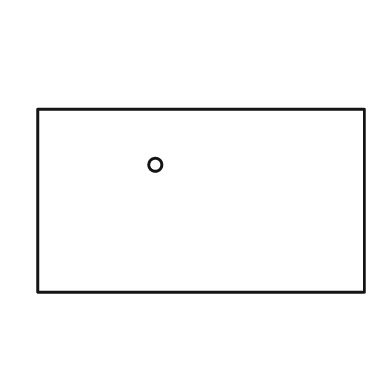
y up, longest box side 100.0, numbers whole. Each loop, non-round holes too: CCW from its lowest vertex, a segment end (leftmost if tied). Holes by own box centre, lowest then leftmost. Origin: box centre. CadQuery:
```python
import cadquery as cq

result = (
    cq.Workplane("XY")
    .moveTo(-50.0, -28.0)
    .lineTo(50.0, -28.0)
    .lineTo(50.0, 28.0)
    .lineTo(-50.0, 28.0)
    .close()
    .moveTo(-14.0, 11.0)
    .circle(2.0)
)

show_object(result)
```